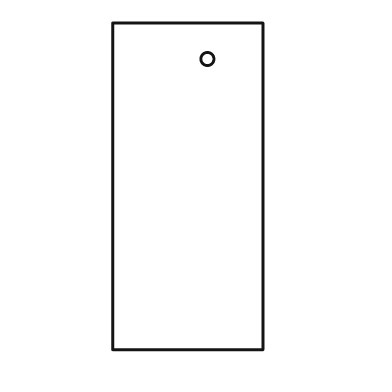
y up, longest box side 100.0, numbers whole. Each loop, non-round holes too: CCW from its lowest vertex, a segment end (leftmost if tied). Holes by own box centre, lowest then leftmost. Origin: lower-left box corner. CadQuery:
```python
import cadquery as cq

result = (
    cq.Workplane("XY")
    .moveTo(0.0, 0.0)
    .lineTo(46.0, 0.0)
    .lineTo(46.0, 100.0)
    .lineTo(0.0, 100.0)
    .close()
    .moveTo(29.0, 89.0)
    .circle(2.0)
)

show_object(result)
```